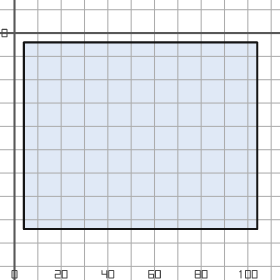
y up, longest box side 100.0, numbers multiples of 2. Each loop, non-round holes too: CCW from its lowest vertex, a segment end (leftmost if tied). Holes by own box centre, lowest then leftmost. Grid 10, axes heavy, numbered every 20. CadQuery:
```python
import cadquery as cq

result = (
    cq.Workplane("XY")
    .moveTo(4.0, -84.0)
    .lineTo(104.0, -84.0)
    .lineTo(104.0, -4.0)
    .lineTo(4.0, -4.0)
    .close()
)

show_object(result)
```